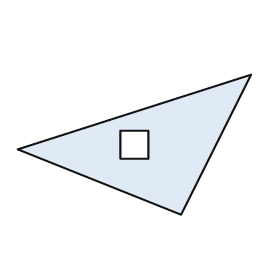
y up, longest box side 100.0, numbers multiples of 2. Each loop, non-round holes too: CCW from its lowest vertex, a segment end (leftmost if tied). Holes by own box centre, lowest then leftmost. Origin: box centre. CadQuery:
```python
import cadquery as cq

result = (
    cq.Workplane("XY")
    .moveTo(20.0, -30.0)
    .lineTo(50.0, 30.0)
    .lineTo(-50.0, -2.0)
    .close()
    .moveTo(-6.0, -6.0)
    .lineTo(6.0, -6.0)
    .lineTo(6.0, 6.0)
    .lineTo(-6.0, 6.0)
    .close()
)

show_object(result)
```